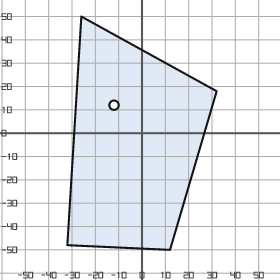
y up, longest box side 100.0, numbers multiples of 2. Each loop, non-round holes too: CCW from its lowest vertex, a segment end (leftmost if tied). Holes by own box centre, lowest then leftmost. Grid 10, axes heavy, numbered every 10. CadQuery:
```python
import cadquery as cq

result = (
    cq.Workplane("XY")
    .moveTo(12.0, -50.0)
    .lineTo(32.0, 18.0)
    .lineTo(-26.0, 50.0)
    .lineTo(-32.0, -48.0)
    .close()
    .moveTo(-12.0, 12.0)
    .circle(2.0)
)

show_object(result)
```